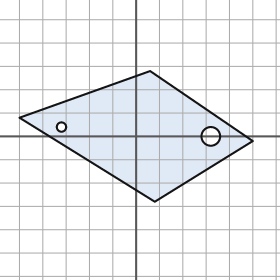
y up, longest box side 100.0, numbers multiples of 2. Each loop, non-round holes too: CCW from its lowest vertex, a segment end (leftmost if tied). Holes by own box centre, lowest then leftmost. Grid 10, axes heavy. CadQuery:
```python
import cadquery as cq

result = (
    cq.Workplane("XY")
    .moveTo(8.0, -28.0)
    .lineTo(50.0, -2.0)
    .lineTo(6.0, 28.0)
    .lineTo(-50.0, 8.0)
    .close()
    .moveTo(32.0, 0.0)
    .circle(4.0)
    .moveTo(-32.0, 4.0)
    .circle(2.0)
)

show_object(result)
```